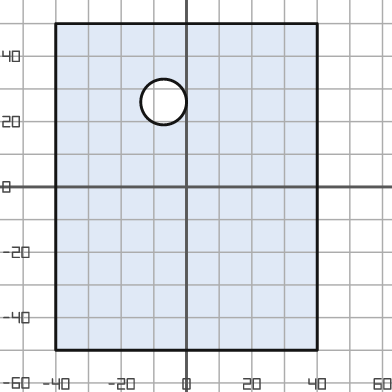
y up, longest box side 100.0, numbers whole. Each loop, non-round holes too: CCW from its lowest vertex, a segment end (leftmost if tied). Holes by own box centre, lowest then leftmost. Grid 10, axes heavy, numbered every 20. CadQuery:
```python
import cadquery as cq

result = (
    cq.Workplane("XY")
    .moveTo(-40.0, -50.0)
    .lineTo(40.0, -50.0)
    .lineTo(40.0, 50.0)
    .lineTo(-40.0, 50.0)
    .close()
    .moveTo(-7.0, 26.0)
    .circle(7.0)
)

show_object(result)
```